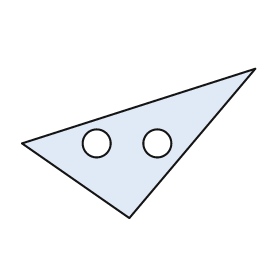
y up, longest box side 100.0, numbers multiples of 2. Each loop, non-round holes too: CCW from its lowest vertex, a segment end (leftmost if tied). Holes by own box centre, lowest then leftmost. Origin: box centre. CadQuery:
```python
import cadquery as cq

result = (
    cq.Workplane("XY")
    .moveTo(-4.0, -32.0)
    .lineTo(50.0, 32.0)
    .lineTo(-50.0, 0.0)
    .close()
    .moveTo(-18.0, 0.0)
    .circle(6.0)
    .moveTo(8.0, 0.0)
    .circle(6.0)
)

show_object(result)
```